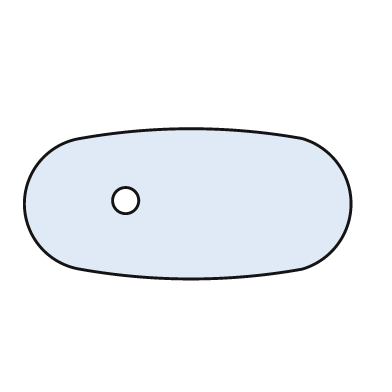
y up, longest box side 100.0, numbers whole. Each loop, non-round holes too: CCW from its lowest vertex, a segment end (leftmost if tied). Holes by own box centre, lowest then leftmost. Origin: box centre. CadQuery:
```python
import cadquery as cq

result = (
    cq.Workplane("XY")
    .moveTo(-33.0, -20.0)
    .threePointArc((1.0, -23.0), (35.0, -20.0))
    .threePointArc((50.0, 0.0), (35.0, 20.0))
    .threePointArc((1.0, 23.0), (-33.0, 20.0))
    .threePointArc((-50.0, 0.0), (-33.0, -20.0))
    .close()
    .moveTo(-19.0, 1.0)
    .circle(4.0)
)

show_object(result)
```